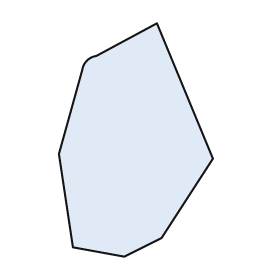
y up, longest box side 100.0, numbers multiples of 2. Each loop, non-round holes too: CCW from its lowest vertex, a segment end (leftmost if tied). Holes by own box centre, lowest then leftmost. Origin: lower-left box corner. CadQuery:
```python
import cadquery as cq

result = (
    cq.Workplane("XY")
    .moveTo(28.0, 0.0)
    .lineTo(44.0, 8.0)
    .lineTo(66.0, 42.0)
    .lineTo(42.0, 100.0)
    .lineTo(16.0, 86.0)
    .threePointArc((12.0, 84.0), (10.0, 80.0))
    .lineTo(0.0, 44.0)
    .lineTo(6.0, 4.0)
    .close()
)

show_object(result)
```